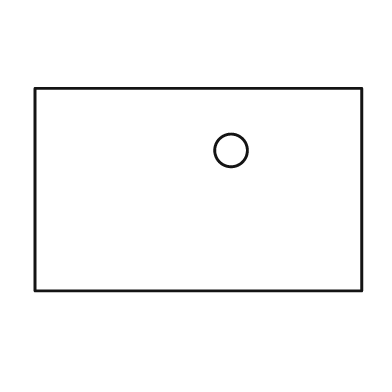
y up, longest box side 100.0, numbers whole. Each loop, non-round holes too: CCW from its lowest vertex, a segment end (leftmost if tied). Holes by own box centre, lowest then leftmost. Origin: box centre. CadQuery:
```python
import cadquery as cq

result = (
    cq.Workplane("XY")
    .moveTo(-50.0, -31.0)
    .lineTo(50.0, -31.0)
    .lineTo(50.0, 31.0)
    .lineTo(-50.0, 31.0)
    .close()
    .moveTo(10.0, 12.0)
    .circle(5.0)
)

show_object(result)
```